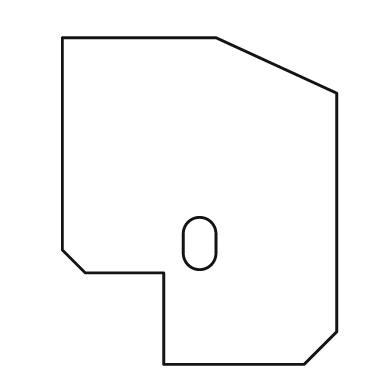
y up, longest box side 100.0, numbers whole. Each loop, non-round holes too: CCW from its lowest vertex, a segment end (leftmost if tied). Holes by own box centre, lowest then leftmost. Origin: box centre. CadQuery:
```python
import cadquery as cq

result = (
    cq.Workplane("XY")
    .moveTo(-11.0, -50.0)
    .lineTo(32.0, -50.0)
    .lineTo(42.0, -40.0)
    .lineTo(42.0, 33.0)
    .lineTo(5.0, 50.0)
    .lineTo(-42.0, 50.0)
    .lineTo(-42.0, -15.0)
    .lineTo(-35.0, -22.0)
    .lineTo(-11.0, -22.0)
    .close()
    .moveTo(-5.0, -16.0)
    .threePointArc((0.0, -21.0), (5.0, -16.0))
    .lineTo(5.0, -10.0)
    .threePointArc((0.0, -5.0), (-5.0, -10.0))
    .close()
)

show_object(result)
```